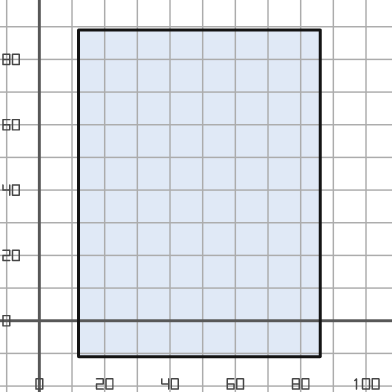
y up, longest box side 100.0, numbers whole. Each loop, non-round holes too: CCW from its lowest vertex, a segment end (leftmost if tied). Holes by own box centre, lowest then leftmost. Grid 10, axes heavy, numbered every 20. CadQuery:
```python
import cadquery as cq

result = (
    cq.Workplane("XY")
    .moveTo(12.0, -11.0)
    .lineTo(86.0, -11.0)
    .lineTo(86.0, 89.0)
    .lineTo(12.0, 89.0)
    .close()
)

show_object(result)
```